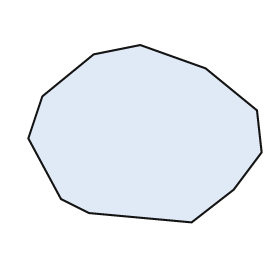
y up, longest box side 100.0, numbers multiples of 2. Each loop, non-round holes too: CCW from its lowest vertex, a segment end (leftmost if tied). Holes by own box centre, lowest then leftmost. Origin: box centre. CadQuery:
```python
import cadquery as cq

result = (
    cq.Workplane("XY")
    .moveTo(20.0, -38.0)
    .lineTo(38.0, -24.0)
    .lineTo(50.0, -8.0)
    .lineTo(48.0, 10.0)
    .lineTo(26.0, 28.0)
    .lineTo(-2.0, 38.0)
    .lineTo(-22.0, 34.0)
    .lineTo(-44.0, 16.0)
    .lineTo(-50.0, -2.0)
    .lineTo(-36.0, -28.0)
    .lineTo(-24.0, -34.0)
    .close()
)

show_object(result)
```